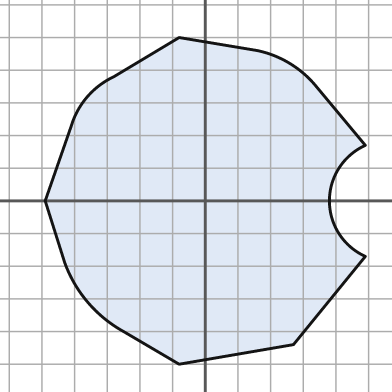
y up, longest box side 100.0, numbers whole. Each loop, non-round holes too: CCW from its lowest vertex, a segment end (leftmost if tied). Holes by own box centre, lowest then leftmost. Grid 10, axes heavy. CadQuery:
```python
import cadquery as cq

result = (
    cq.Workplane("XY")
    .moveTo(-8.0, -50.0)
    .lineTo(27.0, -44.0)
    .lineTo(49.0, -17.0)
    .threePointArc((38.0, 0.0), (49.0, 17.0))
    .lineTo(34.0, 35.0)
    .threePointArc((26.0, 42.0), (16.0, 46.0))
    .lineTo(-8.0, 50.0)
    .lineTo(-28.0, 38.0)
    .threePointArc((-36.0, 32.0), (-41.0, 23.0))
    .lineTo(-49.0, 0.0)
    .lineTo(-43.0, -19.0)
    .threePointArc((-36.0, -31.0), (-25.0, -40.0))
    .close()
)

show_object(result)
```